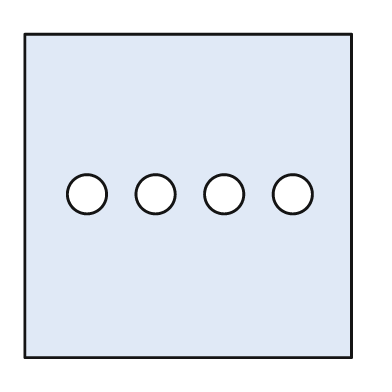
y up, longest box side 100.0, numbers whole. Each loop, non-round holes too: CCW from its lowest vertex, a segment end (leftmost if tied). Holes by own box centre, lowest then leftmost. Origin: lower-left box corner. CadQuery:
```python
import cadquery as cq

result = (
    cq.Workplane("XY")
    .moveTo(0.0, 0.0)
    .lineTo(100.0, 0.0)
    .lineTo(100.0, 99.0)
    .lineTo(0.0, 99.0)
    .close()
    .moveTo(19.0, 50.0)
    .circle(6.0)
    .moveTo(40.0, 50.0)
    .circle(6.0)
    .moveTo(61.0, 50.0)
    .circle(6.0)
    .moveTo(82.0, 50.0)
    .circle(6.0)
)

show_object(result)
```